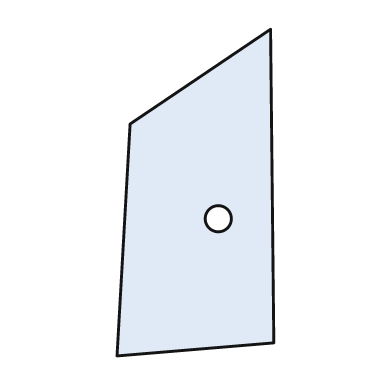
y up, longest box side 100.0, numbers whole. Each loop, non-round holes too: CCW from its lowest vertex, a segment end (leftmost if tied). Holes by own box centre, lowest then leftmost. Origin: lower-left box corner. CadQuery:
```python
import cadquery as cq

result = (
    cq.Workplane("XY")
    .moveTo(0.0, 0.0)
    .lineTo(48.0, 4.0)
    .lineTo(47.0, 100.0)
    .lineTo(4.0, 71.0)
    .close()
    .moveTo(31.0, 42.0)
    .circle(4.0)
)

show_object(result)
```